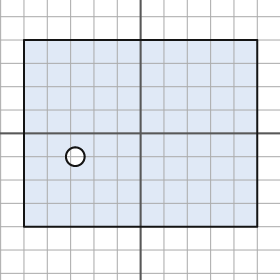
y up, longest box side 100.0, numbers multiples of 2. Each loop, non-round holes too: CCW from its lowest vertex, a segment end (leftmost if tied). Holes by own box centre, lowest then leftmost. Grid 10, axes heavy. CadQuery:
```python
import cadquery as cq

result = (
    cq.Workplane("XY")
    .moveTo(-50.0, -40.0)
    .lineTo(50.0, -40.0)
    .lineTo(50.0, 40.0)
    .lineTo(-50.0, 40.0)
    .close()
    .moveTo(-28.0, -10.0)
    .circle(4.0)
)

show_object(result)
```